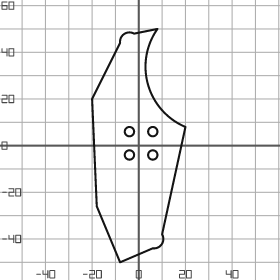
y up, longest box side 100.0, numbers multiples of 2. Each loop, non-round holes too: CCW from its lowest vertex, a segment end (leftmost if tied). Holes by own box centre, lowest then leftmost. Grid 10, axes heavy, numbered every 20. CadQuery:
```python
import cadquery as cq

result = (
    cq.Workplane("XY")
    .moveTo(-8.0, -50.0)
    .lineTo(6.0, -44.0)
    .threePointArc((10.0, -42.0), (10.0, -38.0))
    .lineTo(20.0, 8.0)
    .threePointArc((4.0, 26.0), (8.0, 50.0))
    .lineTo(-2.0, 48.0)
    .threePointArc((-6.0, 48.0), (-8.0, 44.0))
    .lineTo(-20.0, 20.0)
    .lineTo(-18.0, -26.0)
    .close()
    .moveTo(-4.0, -4.0)
    .circle(2.0)
    .moveTo(6.0, -4.0)
    .circle(2.0)
    .moveTo(-4.0, 6.0)
    .circle(2.0)
    .moveTo(6.0, 6.0)
    .circle(2.0)
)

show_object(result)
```